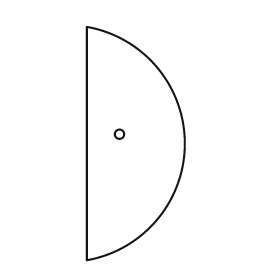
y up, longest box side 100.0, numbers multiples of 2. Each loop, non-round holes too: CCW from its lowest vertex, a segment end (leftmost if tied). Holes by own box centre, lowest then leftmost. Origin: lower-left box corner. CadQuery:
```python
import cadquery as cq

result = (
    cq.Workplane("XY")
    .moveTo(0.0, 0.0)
    .threePointArc((42.0, 50.0), (0.0, 100.0))
    .close()
    .moveTo(14.0, 54.0)
    .circle(2.0)
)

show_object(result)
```